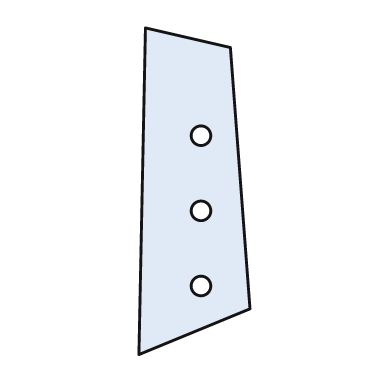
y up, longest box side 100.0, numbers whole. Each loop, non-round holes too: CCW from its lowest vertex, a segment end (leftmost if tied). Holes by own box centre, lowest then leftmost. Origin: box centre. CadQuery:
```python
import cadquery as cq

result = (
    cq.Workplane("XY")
    .moveTo(-17.0, -50.0)
    .lineTo(17.0, -36.0)
    .lineTo(11.0, 44.0)
    .lineTo(-15.0, 50.0)
    .close()
    .moveTo(2.0, -29.0)
    .circle(3.0)
    .moveTo(2.0, -6.0)
    .circle(3.0)
    .moveTo(2.0, 17.0)
    .circle(3.0)
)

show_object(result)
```